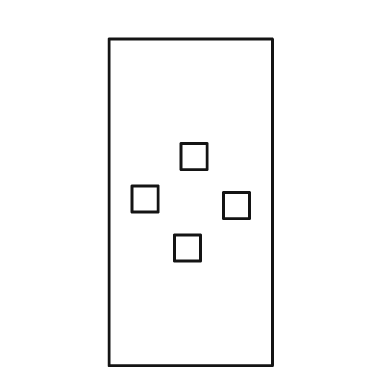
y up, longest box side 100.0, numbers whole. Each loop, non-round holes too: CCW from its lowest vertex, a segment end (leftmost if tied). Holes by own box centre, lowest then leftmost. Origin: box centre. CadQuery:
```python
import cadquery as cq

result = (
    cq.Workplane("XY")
    .moveTo(-25.0, -50.0)
    .lineTo(25.0, -50.0)
    .lineTo(25.0, 50.0)
    .lineTo(-25.0, 50.0)
    .close()
    .moveTo(-5.0, -18.0)
    .lineTo(3.0, -18.0)
    .lineTo(3.0, -10.0)
    .lineTo(-5.0, -10.0)
    .close()
    .moveTo(10.0, -5.0)
    .lineTo(18.0, -5.0)
    .lineTo(18.0, 3.0)
    .lineTo(10.0, 3.0)
    .close()
    .moveTo(-18.0, -3.0)
    .lineTo(-10.0, -3.0)
    .lineTo(-10.0, 5.0)
    .lineTo(-18.0, 5.0)
    .close()
    .moveTo(-3.0, 10.0)
    .lineTo(5.0, 10.0)
    .lineTo(5.0, 18.0)
    .lineTo(-3.0, 18.0)
    .close()
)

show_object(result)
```